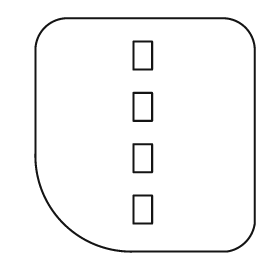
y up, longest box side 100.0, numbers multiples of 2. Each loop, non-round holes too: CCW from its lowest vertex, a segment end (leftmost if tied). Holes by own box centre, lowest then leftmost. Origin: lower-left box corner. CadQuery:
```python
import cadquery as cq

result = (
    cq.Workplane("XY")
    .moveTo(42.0, 0.0)
    .lineTo(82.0, 0.0)
    .threePointArc((90.0, 4.0), (94.0, 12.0))
    .lineTo(94.0, 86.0)
    .threePointArc((90.0, 96.0), (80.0, 100.0))
    .lineTo(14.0, 100.0)
    .threePointArc((4.0, 96.0), (0.0, 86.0))
    .lineTo(0.0, 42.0)
    .threePointArc((12.0, 12.0), (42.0, 0.0))
    .close()
    .moveTo(42.0, 12.0)
    .lineTo(50.0, 12.0)
    .lineTo(50.0, 24.0)
    .lineTo(42.0, 24.0)
    .close()
    .moveTo(42.0, 34.0)
    .lineTo(50.0, 34.0)
    .lineTo(50.0, 46.0)
    .lineTo(42.0, 46.0)
    .close()
    .moveTo(42.0, 56.0)
    .lineTo(50.0, 56.0)
    .lineTo(50.0, 68.0)
    .lineTo(42.0, 68.0)
    .close()
    .moveTo(42.0, 78.0)
    .lineTo(50.0, 78.0)
    .lineTo(50.0, 90.0)
    .lineTo(42.0, 90.0)
    .close()
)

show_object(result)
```